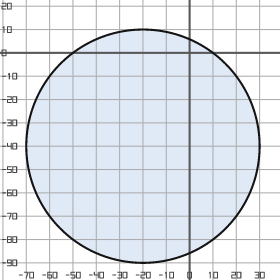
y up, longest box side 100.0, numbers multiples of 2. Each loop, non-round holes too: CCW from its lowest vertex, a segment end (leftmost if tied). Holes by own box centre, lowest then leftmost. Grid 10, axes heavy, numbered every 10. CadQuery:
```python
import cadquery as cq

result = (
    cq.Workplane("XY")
    .moveTo(-20.0, -40.0)
    .circle(50.0)
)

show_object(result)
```